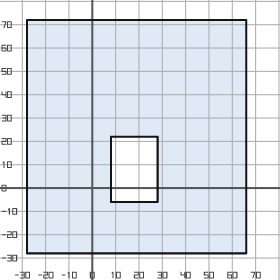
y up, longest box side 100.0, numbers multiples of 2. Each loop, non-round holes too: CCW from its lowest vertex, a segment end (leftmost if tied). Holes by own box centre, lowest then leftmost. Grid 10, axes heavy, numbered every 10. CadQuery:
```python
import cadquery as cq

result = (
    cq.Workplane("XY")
    .moveTo(-28.0, -28.0)
    .lineTo(66.0, -28.0)
    .lineTo(66.0, 72.0)
    .lineTo(-28.0, 72.0)
    .close()
    .moveTo(8.0, -6.0)
    .lineTo(28.0, -6.0)
    .lineTo(28.0, 22.0)
    .lineTo(8.0, 22.0)
    .close()
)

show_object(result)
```